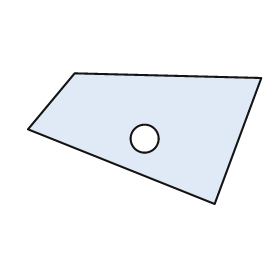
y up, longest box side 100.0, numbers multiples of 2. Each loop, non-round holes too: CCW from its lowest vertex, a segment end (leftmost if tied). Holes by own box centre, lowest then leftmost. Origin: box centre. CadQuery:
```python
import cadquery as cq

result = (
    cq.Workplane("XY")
    .moveTo(30.0, -28.0)
    .lineTo(50.0, 26.0)
    .lineTo(-30.0, 28.0)
    .lineTo(-50.0, 4.0)
    .close()
    .moveTo(0.0, 0.0)
    .circle(6.0)
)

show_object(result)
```